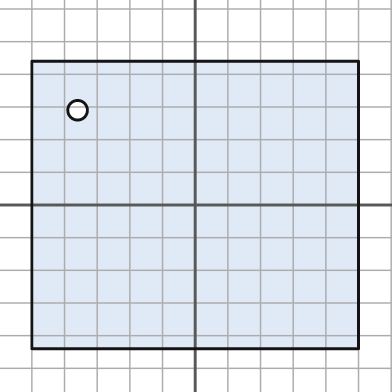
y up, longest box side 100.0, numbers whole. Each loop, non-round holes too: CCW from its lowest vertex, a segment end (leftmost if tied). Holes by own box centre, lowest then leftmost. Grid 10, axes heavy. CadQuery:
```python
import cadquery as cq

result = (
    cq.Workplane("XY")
    .moveTo(-50.0, -44.0)
    .lineTo(50.0, -44.0)
    .lineTo(50.0, 44.0)
    .lineTo(-50.0, 44.0)
    .close()
    .moveTo(-36.0, 29.0)
    .circle(3.0)
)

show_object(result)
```